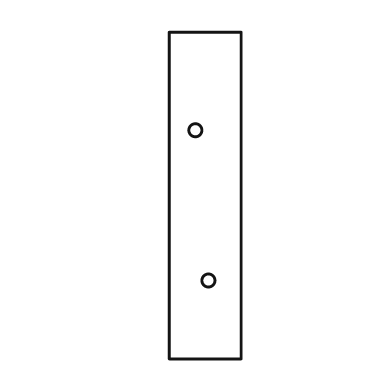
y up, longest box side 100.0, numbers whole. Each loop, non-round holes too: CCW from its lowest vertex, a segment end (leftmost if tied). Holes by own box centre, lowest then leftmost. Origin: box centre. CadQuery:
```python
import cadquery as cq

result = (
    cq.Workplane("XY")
    .moveTo(-11.0, -50.0)
    .lineTo(11.0, -50.0)
    .lineTo(11.0, 50.0)
    .lineTo(-11.0, 50.0)
    .close()
    .moveTo(1.0, -26.0)
    .circle(2.0)
    .moveTo(-3.0, 20.0)
    .circle(2.0)
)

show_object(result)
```